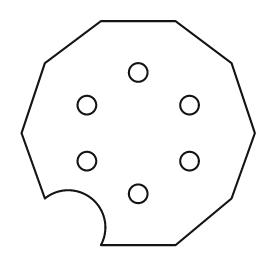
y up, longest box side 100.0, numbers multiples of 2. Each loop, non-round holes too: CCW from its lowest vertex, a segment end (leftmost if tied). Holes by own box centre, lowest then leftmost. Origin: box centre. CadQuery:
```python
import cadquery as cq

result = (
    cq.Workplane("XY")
    .moveTo(-16.0, -48.0)
    .lineTo(16.0, -48.0)
    .lineTo(40.0, -28.0)
    .lineTo(50.0, 0.0)
    .lineTo(40.0, 30.0)
    .lineTo(16.0, 48.0)
    .lineTo(-16.0, 48.0)
    .lineTo(-40.0, 30.0)
    .lineTo(-50.0, 0.0)
    .lineTo(-40.0, -28.0)
    .threePointArc((-20.0, -28.0), (-16.0, -48.0))
    .close()
    .moveTo(0.0, -26.0)
    .circle(4.0)
    .moveTo(-22.0, -12.0)
    .circle(4.0)
    .moveTo(22.0, -12.0)
    .circle(4.0)
    .moveTo(-22.0, 12.0)
    .circle(4.0)
    .moveTo(22.0, 12.0)
    .circle(4.0)
    .moveTo(0.0, 26.0)
    .circle(4.0)
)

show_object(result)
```